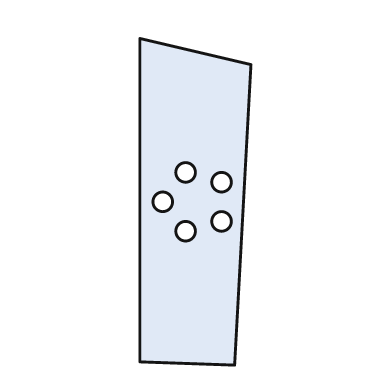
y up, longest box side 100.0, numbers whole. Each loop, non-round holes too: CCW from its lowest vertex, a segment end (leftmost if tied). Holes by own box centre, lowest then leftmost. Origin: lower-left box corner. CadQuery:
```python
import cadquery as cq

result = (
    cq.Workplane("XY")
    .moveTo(29.0, 0.0)
    .lineTo(34.0, 92.0)
    .lineTo(0.0, 100.0)
    .lineTo(0.0, 1.0)
    .close()
    .moveTo(14.0, 41.0)
    .circle(3.0)
    .moveTo(25.0, 44.0)
    .circle(3.0)
    .moveTo(7.0, 50.0)
    .circle(3.0)
    .moveTo(25.0, 56.0)
    .circle(3.0)
    .moveTo(14.0, 59.0)
    .circle(3.0)
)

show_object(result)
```